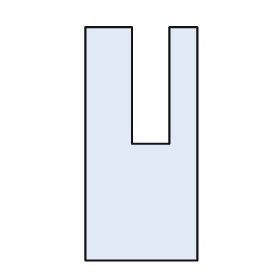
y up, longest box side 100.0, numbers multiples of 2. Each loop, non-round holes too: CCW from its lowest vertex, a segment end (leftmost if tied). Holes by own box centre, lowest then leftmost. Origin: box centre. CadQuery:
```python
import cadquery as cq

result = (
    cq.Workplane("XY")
    .moveTo(-24.0, -50.0)
    .lineTo(24.0, -50.0)
    .lineTo(24.0, 50.0)
    .lineTo(12.0, 50.0)
    .lineTo(12.0, 0.0)
    .lineTo(-4.0, 0.0)
    .lineTo(-4.0, 50.0)
    .lineTo(-24.0, 50.0)
    .close()
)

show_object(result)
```